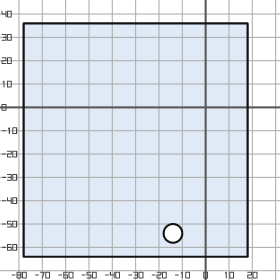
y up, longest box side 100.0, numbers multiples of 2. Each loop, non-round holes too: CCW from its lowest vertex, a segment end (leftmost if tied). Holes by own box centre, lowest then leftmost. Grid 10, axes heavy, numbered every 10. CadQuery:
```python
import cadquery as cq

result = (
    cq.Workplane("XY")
    .moveTo(-78.0, -64.0)
    .lineTo(18.0, -64.0)
    .lineTo(18.0, 36.0)
    .lineTo(-78.0, 36.0)
    .close()
    .moveTo(-14.0, -54.0)
    .circle(4.0)
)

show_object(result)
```